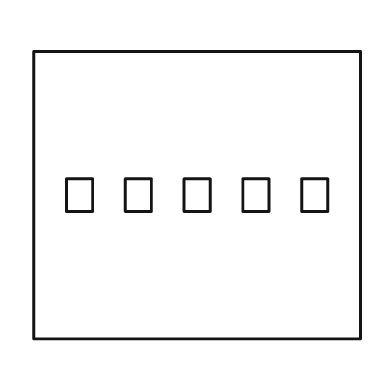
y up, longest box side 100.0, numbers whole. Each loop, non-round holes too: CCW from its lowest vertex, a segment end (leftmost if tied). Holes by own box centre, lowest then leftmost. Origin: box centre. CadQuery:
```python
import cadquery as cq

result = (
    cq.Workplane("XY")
    .moveTo(-50.0, -44.0)
    .lineTo(50.0, -44.0)
    .lineTo(50.0, 44.0)
    .lineTo(-50.0, 44.0)
    .close()
    .moveTo(-40.0, -5.0)
    .lineTo(-32.0, -5.0)
    .lineTo(-32.0, 5.0)
    .lineTo(-40.0, 5.0)
    .close()
    .moveTo(-22.0, -5.0)
    .lineTo(-14.0, -5.0)
    .lineTo(-14.0, 5.0)
    .lineTo(-22.0, 5.0)
    .close()
    .moveTo(-4.0, -5.0)
    .lineTo(4.0, -5.0)
    .lineTo(4.0, 5.0)
    .lineTo(-4.0, 5.0)
    .close()
    .moveTo(14.0, -5.0)
    .lineTo(22.0, -5.0)
    .lineTo(22.0, 5.0)
    .lineTo(14.0, 5.0)
    .close()
    .moveTo(32.0, -5.0)
    .lineTo(40.0, -5.0)
    .lineTo(40.0, 5.0)
    .lineTo(32.0, 5.0)
    .close()
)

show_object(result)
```